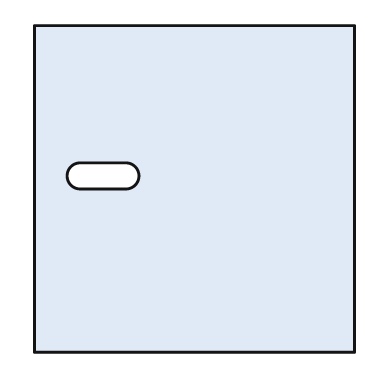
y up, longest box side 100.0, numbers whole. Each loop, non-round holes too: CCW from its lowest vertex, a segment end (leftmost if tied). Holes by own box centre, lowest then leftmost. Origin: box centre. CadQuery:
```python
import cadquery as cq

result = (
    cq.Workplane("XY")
    .moveTo(-49.0, -50.0)
    .lineTo(49.0, -50.0)
    .lineTo(49.0, 50.0)
    .lineTo(-49.0, 50.0)
    .close()
    .moveTo(-35.0, 0.0)
    .lineTo(-21.0, 0.0)
    .threePointArc((-17.0, 4.0), (-21.0, 8.0))
    .lineTo(-35.0, 8.0)
    .threePointArc((-39.0, 4.0), (-35.0, 0.0))
    .close()
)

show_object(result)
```